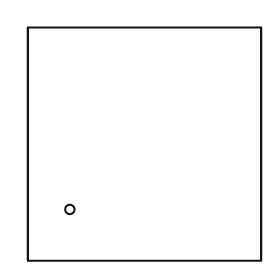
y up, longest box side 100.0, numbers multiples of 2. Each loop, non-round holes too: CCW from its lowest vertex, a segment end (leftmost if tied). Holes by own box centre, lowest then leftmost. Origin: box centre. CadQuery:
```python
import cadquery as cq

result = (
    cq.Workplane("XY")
    .moveTo(-50.0, -50.0)
    .lineTo(50.0, -50.0)
    .lineTo(50.0, 50.0)
    .lineTo(-50.0, 50.0)
    .close()
    .moveTo(-32.0, -28.0)
    .circle(2.0)
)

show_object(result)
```